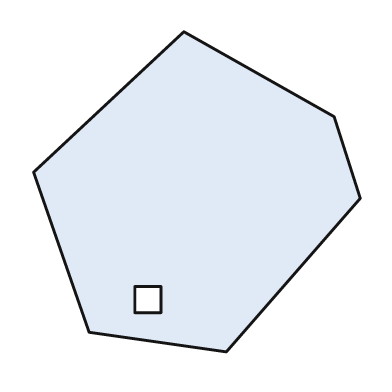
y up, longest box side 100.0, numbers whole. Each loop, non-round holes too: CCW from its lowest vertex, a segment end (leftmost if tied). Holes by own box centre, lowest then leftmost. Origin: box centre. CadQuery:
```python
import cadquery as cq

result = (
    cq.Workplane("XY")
    .moveTo(9.0, -49.0)
    .lineTo(50.0, -2.0)
    .lineTo(42.0, 23.0)
    .lineTo(-4.0, 49.0)
    .lineTo(-50.0, 6.0)
    .lineTo(-33.0, -43.0)
    .close()
    .moveTo(-19.0, -37.0)
    .lineTo(-11.0, -37.0)
    .lineTo(-11.0, -29.0)
    .lineTo(-19.0, -29.0)
    .close()
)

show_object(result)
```